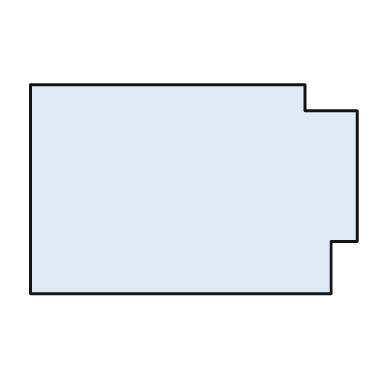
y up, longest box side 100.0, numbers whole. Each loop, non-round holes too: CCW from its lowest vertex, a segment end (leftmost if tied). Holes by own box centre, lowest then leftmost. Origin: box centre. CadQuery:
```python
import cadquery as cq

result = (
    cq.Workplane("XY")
    .moveTo(-50.0, -32.0)
    .lineTo(42.0, -32.0)
    .lineTo(42.0, -16.0)
    .lineTo(50.0, -16.0)
    .lineTo(50.0, 24.0)
    .lineTo(34.0, 24.0)
    .lineTo(34.0, 32.0)
    .lineTo(-50.0, 32.0)
    .close()
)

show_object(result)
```